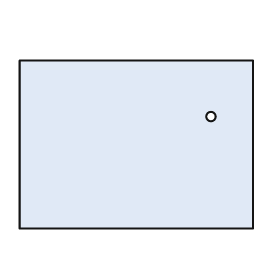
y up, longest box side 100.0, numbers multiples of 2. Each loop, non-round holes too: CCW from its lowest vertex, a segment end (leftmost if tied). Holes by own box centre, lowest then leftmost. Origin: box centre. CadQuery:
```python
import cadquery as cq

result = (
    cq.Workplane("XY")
    .moveTo(-50.0, -36.0)
    .lineTo(50.0, -36.0)
    .lineTo(50.0, 36.0)
    .lineTo(-50.0, 36.0)
    .close()
    .moveTo(32.0, 12.0)
    .circle(2.0)
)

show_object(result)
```